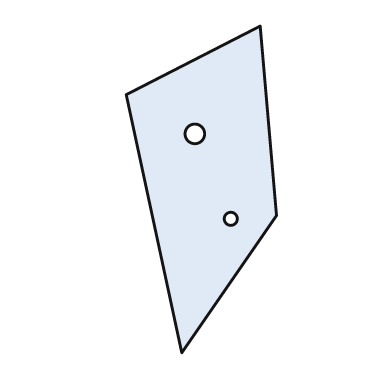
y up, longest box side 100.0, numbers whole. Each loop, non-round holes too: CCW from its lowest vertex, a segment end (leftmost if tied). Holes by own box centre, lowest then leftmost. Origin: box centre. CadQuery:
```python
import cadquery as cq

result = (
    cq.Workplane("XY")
    .moveTo(-6.0, -50.0)
    .lineTo(23.0, -8.0)
    .lineTo(18.0, 50.0)
    .lineTo(-23.0, 29.0)
    .close()
    .moveTo(9.0, -9.0)
    .circle(2.0)
    .moveTo(-2.0, 17.0)
    .circle(3.0)
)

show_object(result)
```